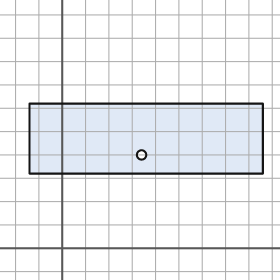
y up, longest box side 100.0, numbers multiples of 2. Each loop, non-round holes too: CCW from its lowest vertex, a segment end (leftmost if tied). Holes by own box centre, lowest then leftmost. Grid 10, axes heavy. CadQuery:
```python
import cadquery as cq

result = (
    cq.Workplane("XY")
    .moveTo(-14.0, 32.0)
    .lineTo(86.0, 32.0)
    .lineTo(86.0, 62.0)
    .lineTo(-14.0, 62.0)
    .close()
    .moveTo(34.0, 40.0)
    .circle(2.0)
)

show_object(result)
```